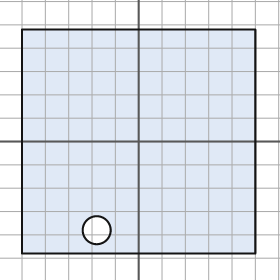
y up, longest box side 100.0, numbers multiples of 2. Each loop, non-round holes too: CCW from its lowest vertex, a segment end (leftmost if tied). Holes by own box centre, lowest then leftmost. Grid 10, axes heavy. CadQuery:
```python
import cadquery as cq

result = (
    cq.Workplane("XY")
    .moveTo(-50.0, -48.0)
    .lineTo(50.0, -48.0)
    .lineTo(50.0, 48.0)
    .lineTo(-50.0, 48.0)
    .close()
    .moveTo(-18.0, -38.0)
    .circle(6.0)
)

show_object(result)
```